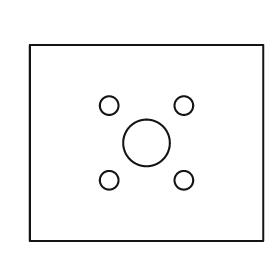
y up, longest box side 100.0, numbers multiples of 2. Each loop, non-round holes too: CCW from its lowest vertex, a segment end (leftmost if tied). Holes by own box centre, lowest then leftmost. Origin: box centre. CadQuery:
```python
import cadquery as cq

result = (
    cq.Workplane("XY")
    .moveTo(-50.0, -42.0)
    .lineTo(50.0, -42.0)
    .lineTo(50.0, 42.0)
    .lineTo(-50.0, 42.0)
    .close()
    .moveTo(-16.0, -16.0)
    .circle(4.0)
    .moveTo(16.0, -16.0)
    .circle(4.0)
    .moveTo(0.0, 0.0)
    .circle(10.0)
    .moveTo(-16.0, 16.0)
    .circle(4.0)
    .moveTo(16.0, 16.0)
    .circle(4.0)
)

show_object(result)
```